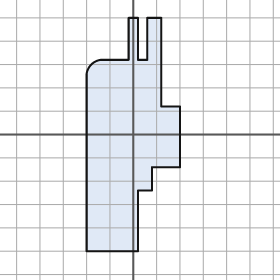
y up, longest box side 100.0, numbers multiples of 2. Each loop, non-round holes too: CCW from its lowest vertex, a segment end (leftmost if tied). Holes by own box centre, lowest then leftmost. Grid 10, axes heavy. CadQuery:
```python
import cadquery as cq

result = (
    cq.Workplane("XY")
    .moveTo(-20.0, -50.0)
    .lineTo(2.0, -50.0)
    .lineTo(2.0, -24.0)
    .lineTo(8.0, -24.0)
    .lineTo(8.0, -14.0)
    .lineTo(20.0, -14.0)
    .lineTo(20.0, 12.0)
    .lineTo(12.0, 12.0)
    .lineTo(12.0, 50.0)
    .lineTo(6.0, 50.0)
    .lineTo(6.0, 32.0)
    .lineTo(2.0, 32.0)
    .lineTo(2.0, 50.0)
    .lineTo(-2.0, 50.0)
    .lineTo(-2.0, 32.0)
    .lineTo(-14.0, 32.0)
    .threePointArc((-18.0, 30.0), (-20.0, 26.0))
    .close()
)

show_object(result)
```